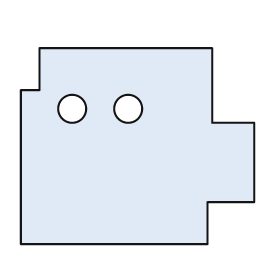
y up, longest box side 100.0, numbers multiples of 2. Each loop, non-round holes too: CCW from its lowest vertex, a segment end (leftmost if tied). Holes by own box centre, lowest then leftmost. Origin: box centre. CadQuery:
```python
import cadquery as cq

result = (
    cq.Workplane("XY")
    .moveTo(-50.0, -42.0)
    .lineTo(30.0, -42.0)
    .lineTo(30.0, -24.0)
    .lineTo(50.0, -24.0)
    .lineTo(50.0, 10.0)
    .lineTo(32.0, 10.0)
    .lineTo(32.0, 42.0)
    .lineTo(-42.0, 42.0)
    .lineTo(-42.0, 24.0)
    .lineTo(-50.0, 24.0)
    .close()
    .moveTo(-28.0, 16.0)
    .circle(6.0)
    .moveTo(-4.0, 16.0)
    .circle(6.0)
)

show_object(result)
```